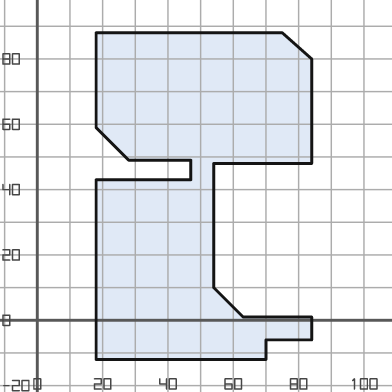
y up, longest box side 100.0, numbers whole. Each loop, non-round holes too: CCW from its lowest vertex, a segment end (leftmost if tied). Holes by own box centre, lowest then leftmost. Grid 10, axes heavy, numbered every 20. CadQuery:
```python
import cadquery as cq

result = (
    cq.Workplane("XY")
    .moveTo(18.0, -12.0)
    .lineTo(70.0, -12.0)
    .lineTo(70.0, -6.0)
    .lineTo(84.0, -6.0)
    .lineTo(84.0, 1.0)
    .lineTo(63.0, 1.0)
    .lineTo(54.0, 10.0)
    .lineTo(54.0, 48.0)
    .lineTo(84.0, 48.0)
    .lineTo(84.0, 80.0)
    .lineTo(75.0, 88.0)
    .lineTo(18.0, 88.0)
    .lineTo(18.0, 59.0)
    .lineTo(28.0, 49.0)
    .lineTo(47.0, 49.0)
    .lineTo(47.0, 43.0)
    .lineTo(18.0, 43.0)
    .close()
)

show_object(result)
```